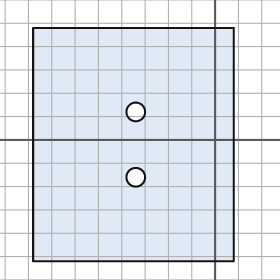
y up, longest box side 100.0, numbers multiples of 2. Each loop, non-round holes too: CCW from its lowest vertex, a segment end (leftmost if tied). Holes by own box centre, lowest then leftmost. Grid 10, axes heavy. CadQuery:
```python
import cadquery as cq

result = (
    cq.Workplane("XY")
    .moveTo(-78.0, -52.0)
    .lineTo(8.0, -52.0)
    .lineTo(8.0, 48.0)
    .lineTo(-78.0, 48.0)
    .close()
    .moveTo(-34.0, -16.0)
    .circle(4.0)
    .moveTo(-34.0, 12.0)
    .circle(4.0)
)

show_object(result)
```